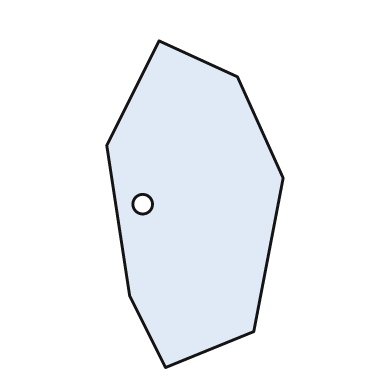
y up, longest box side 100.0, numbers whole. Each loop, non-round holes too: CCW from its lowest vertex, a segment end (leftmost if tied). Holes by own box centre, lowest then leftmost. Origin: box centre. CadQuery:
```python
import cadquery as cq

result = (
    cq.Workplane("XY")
    .moveTo(-9.0, -50.0)
    .lineTo(18.0, -39.0)
    .lineTo(27.0, 8.0)
    .lineTo(13.0, 39.0)
    .lineTo(-11.0, 50.0)
    .lineTo(-27.0, 18.0)
    .lineTo(-20.0, -28.0)
    .close()
    .moveTo(-16.0, 0.0)
    .circle(3.0)
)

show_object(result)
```